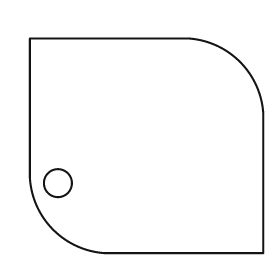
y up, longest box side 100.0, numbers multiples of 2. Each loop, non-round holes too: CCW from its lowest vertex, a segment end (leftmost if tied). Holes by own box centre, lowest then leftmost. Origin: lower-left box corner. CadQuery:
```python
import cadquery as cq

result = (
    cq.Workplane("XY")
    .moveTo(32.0, 0.0)
    .lineTo(100.0, 0.0)
    .lineTo(100.0, 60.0)
    .threePointArc((90.0, 82.0), (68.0, 92.0))
    .lineTo(0.0, 92.0)
    .lineTo(0.0, 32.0)
    .threePointArc((10.0, 10.0), (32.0, 0.0))
    .close()
    .moveTo(12.0, 30.0)
    .circle(6.0)
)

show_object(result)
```